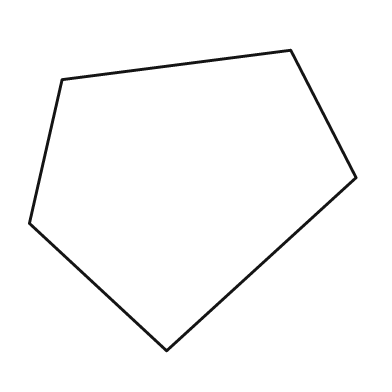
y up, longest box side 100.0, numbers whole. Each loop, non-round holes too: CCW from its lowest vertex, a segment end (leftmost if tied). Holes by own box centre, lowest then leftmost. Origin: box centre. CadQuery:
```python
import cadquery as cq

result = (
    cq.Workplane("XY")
    .moveTo(-8.0, -46.0)
    .lineTo(50.0, 7.0)
    .lineTo(30.0, 46.0)
    .lineTo(-40.0, 37.0)
    .lineTo(-50.0, -7.0)
    .close()
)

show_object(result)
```